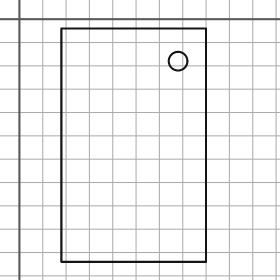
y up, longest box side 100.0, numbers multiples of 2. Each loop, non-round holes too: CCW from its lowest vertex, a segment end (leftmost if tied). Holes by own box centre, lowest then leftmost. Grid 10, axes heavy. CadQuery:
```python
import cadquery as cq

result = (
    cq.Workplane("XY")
    .moveTo(18.0, -104.0)
    .lineTo(80.0, -104.0)
    .lineTo(80.0, -4.0)
    .lineTo(18.0, -4.0)
    .close()
    .moveTo(68.0, -18.0)
    .circle(4.0)
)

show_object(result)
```